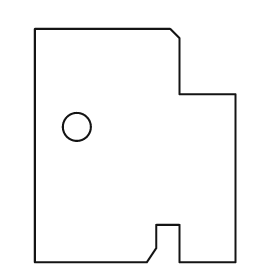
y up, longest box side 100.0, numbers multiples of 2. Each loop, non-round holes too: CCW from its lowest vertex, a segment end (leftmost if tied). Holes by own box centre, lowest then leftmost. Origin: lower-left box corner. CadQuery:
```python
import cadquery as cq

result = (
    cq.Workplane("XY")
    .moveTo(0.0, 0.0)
    .lineTo(48.0, 0.0)
    .lineTo(52.0, 6.0)
    .lineTo(52.0, 16.0)
    .lineTo(62.0, 16.0)
    .lineTo(62.0, 0.0)
    .lineTo(86.0, 0.0)
    .lineTo(86.0, 72.0)
    .lineTo(62.0, 72.0)
    .lineTo(62.0, 96.0)
    .lineTo(58.0, 100.0)
    .lineTo(0.0, 100.0)
    .close()
    .moveTo(18.0, 58.0)
    .circle(6.0)
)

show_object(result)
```